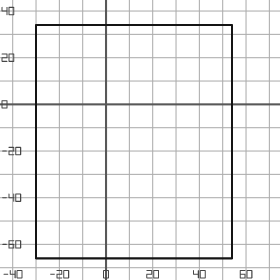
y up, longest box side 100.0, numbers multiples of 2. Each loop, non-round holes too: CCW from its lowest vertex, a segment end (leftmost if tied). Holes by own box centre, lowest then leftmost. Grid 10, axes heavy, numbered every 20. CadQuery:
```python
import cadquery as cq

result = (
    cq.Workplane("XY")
    .moveTo(-30.0, -66.0)
    .lineTo(54.0, -66.0)
    .lineTo(54.0, 34.0)
    .lineTo(-30.0, 34.0)
    .close()
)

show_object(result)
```